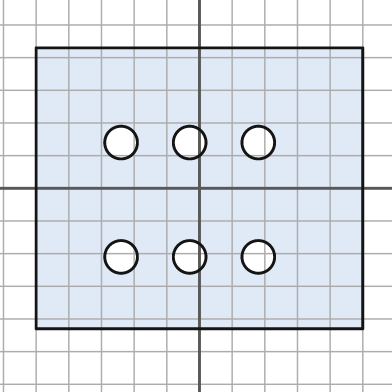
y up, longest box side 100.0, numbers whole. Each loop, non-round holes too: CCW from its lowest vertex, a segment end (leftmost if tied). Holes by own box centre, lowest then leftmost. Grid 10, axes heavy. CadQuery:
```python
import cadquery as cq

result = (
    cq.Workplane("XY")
    .moveTo(-50.0, -43.0)
    .lineTo(50.0, -43.0)
    .lineTo(50.0, 43.0)
    .lineTo(-50.0, 43.0)
    .close()
    .moveTo(-24.0, -21.0)
    .circle(5.0)
    .moveTo(-3.0, -21.0)
    .circle(5.0)
    .moveTo(18.0, -21.0)
    .circle(5.0)
    .moveTo(-24.0, 14.0)
    .circle(5.0)
    .moveTo(-3.0, 14.0)
    .circle(5.0)
    .moveTo(18.0, 14.0)
    .circle(5.0)
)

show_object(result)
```